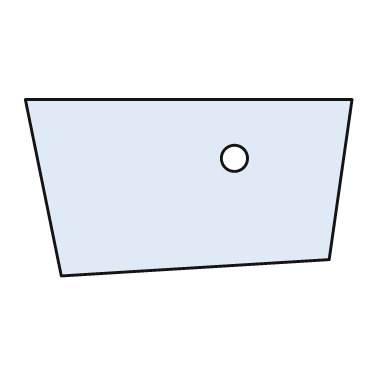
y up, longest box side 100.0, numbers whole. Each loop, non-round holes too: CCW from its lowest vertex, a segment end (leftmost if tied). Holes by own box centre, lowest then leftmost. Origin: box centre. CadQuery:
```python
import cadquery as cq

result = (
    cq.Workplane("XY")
    .moveTo(-39.0, -27.0)
    .lineTo(43.0, -22.0)
    .lineTo(50.0, 27.0)
    .lineTo(-50.0, 27.0)
    .close()
    .moveTo(14.0, 9.0)
    .circle(4.0)
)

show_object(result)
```